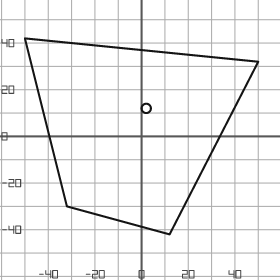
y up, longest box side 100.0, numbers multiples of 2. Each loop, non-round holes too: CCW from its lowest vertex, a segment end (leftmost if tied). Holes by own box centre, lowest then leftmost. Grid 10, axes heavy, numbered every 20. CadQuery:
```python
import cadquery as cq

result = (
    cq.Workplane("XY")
    .moveTo(12.0, -42.0)
    .lineTo(50.0, 32.0)
    .lineTo(-50.0, 42.0)
    .lineTo(-32.0, -30.0)
    .close()
    .moveTo(2.0, 12.0)
    .circle(2.0)
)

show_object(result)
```